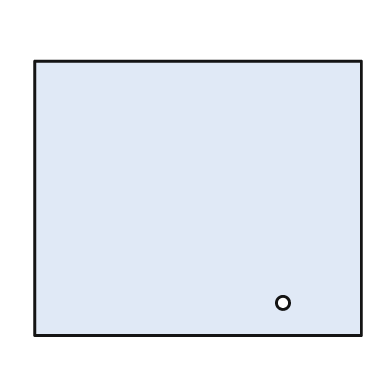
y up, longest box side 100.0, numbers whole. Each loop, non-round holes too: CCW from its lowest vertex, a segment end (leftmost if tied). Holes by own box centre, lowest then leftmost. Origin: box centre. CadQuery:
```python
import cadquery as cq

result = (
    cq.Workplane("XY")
    .moveTo(-50.0, -42.0)
    .lineTo(50.0, -42.0)
    .lineTo(50.0, 42.0)
    .lineTo(-50.0, 42.0)
    .close()
    .moveTo(26.0, -32.0)
    .circle(2.0)
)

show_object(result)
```